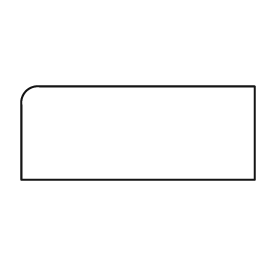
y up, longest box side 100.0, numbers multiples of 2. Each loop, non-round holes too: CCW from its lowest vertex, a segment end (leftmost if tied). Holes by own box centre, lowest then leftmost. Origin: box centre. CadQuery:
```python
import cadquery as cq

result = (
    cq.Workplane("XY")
    .moveTo(-50.0, -20.0)
    .lineTo(50.0, -20.0)
    .lineTo(50.0, 20.0)
    .lineTo(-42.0, 20.0)
    .threePointArc((-48.0, 18.0), (-50.0, 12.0))
    .close()
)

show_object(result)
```